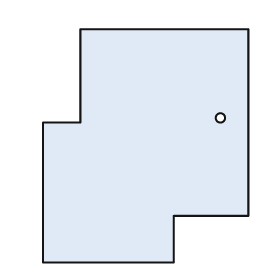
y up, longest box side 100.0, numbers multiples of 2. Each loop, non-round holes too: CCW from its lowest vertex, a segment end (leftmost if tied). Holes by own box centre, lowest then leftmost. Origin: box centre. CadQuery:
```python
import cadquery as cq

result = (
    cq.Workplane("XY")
    .moveTo(-44.0, -50.0)
    .lineTo(12.0, -50.0)
    .lineTo(12.0, -30.0)
    .lineTo(44.0, -30.0)
    .lineTo(44.0, 50.0)
    .lineTo(-28.0, 50.0)
    .lineTo(-28.0, 10.0)
    .lineTo(-44.0, 10.0)
    .close()
    .moveTo(32.0, 12.0)
    .circle(2.0)
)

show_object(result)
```